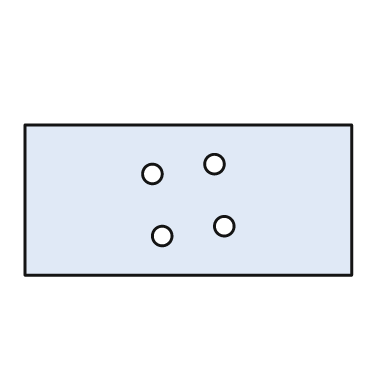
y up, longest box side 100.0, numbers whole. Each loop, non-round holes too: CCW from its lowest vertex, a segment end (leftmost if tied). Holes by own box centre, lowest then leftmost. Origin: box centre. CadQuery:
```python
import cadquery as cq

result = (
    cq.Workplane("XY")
    .moveTo(-50.0, -23.0)
    .lineTo(50.0, -23.0)
    .lineTo(50.0, 23.0)
    .lineTo(-50.0, 23.0)
    .close()
    .moveTo(-8.0, -11.0)
    .circle(3.0)
    .moveTo(11.0, -8.0)
    .circle(3.0)
    .moveTo(-11.0, 8.0)
    .circle(3.0)
    .moveTo(8.0, 11.0)
    .circle(3.0)
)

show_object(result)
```